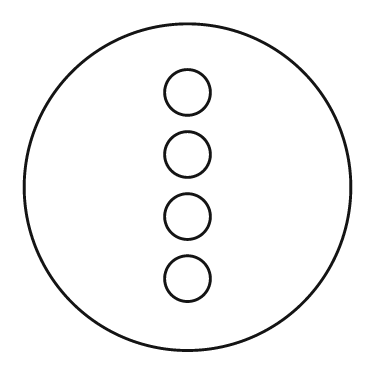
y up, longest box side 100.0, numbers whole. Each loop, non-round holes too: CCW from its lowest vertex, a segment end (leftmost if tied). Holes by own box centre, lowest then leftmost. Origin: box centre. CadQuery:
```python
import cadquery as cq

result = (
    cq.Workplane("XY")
    .moveTo(0.0, 0.0)
    .circle(50.0)
    .moveTo(0.0, -28.0)
    .circle(7.0)
    .moveTo(0.0, -9.0)
    .circle(7.0)
    .moveTo(0.0, 10.0)
    .circle(7.0)
    .moveTo(0.0, 29.0)
    .circle(7.0)
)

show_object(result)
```